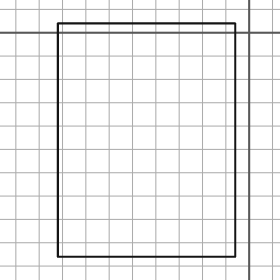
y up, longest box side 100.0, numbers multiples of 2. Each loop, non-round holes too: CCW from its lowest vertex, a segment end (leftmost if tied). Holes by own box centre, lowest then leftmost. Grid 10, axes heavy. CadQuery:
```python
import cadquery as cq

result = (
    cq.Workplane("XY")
    .moveTo(-82.0, -96.0)
    .lineTo(-6.0, -96.0)
    .lineTo(-6.0, 4.0)
    .lineTo(-82.0, 4.0)
    .close()
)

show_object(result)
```